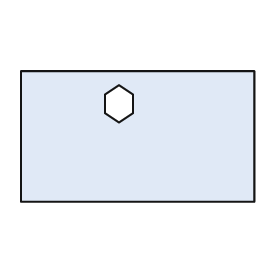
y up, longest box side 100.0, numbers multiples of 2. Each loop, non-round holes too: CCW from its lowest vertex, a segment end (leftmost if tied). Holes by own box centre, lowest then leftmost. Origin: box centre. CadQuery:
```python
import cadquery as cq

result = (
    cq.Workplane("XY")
    .moveTo(-50.0, -28.0)
    .lineTo(50.0, -28.0)
    .lineTo(50.0, 28.0)
    .lineTo(-50.0, 28.0)
    .close()
    .moveTo(-8.0, 6.0)
    .lineTo(-2.0, 10.0)
    .lineTo(-2.0, 18.0)
    .lineTo(-8.0, 22.0)
    .lineTo(-14.0, 18.0)
    .lineTo(-14.0, 10.0)
    .close()
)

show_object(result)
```